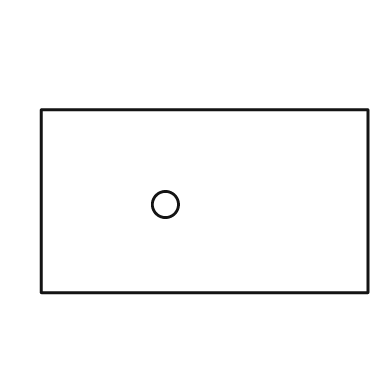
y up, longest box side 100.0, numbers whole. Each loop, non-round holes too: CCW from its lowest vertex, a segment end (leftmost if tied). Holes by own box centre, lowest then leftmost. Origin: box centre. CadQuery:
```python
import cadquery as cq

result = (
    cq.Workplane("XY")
    .moveTo(-50.0, -28.0)
    .lineTo(50.0, -28.0)
    .lineTo(50.0, 28.0)
    .lineTo(-50.0, 28.0)
    .close()
    .moveTo(-12.0, -1.0)
    .circle(4.0)
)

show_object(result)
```